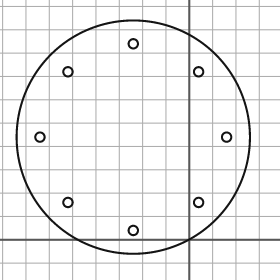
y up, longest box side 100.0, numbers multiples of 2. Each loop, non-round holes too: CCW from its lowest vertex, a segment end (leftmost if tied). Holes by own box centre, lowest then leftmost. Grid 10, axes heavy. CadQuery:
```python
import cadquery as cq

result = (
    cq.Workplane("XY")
    .moveTo(-24.0, 44.0)
    .circle(50.0)
    .moveTo(-24.0, 4.0)
    .circle(2.0)
    .moveTo(-52.0, 16.0)
    .circle(2.0)
    .moveTo(4.0, 16.0)
    .circle(2.0)
    .moveTo(-64.0, 44.0)
    .circle(2.0)
    .moveTo(16.0, 44.0)
    .circle(2.0)
    .moveTo(-52.0, 72.0)
    .circle(2.0)
    .moveTo(4.0, 72.0)
    .circle(2.0)
    .moveTo(-24.0, 84.0)
    .circle(2.0)
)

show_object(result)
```